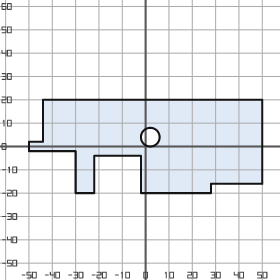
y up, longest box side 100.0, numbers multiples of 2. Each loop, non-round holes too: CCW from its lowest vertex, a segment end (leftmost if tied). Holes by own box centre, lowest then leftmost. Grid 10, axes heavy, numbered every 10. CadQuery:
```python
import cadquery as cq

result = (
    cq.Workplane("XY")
    .moveTo(-30.0, -20.0)
    .lineTo(-22.0, -20.0)
    .lineTo(-22.0, -4.0)
    .lineTo(-2.0, -4.0)
    .lineTo(-2.0, -20.0)
    .lineTo(28.0, -20.0)
    .lineTo(28.0, -16.0)
    .lineTo(50.0, -16.0)
    .lineTo(50.0, 20.0)
    .lineTo(-44.0, 20.0)
    .lineTo(-44.0, 2.0)
    .lineTo(-50.0, 2.0)
    .lineTo(-50.0, -2.0)
    .lineTo(-30.0, -2.0)
    .close()
    .moveTo(2.0, 4.0)
    .circle(4.0)
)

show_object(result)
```